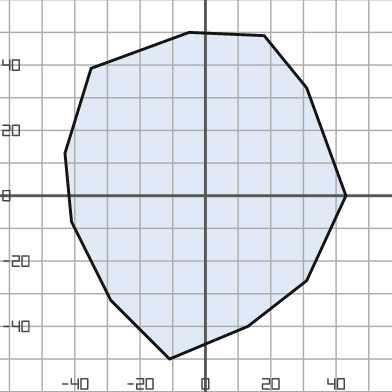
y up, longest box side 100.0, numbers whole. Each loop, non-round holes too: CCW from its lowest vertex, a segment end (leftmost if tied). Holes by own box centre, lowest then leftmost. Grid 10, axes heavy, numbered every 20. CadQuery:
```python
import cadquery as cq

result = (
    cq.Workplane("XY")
    .moveTo(-11.0, -50.0)
    .lineTo(13.0, -40.0)
    .lineTo(31.0, -26.0)
    .lineTo(43.0, 0.0)
    .lineTo(31.0, 33.0)
    .lineTo(18.0, 49.0)
    .lineTo(-5.0, 50.0)
    .lineTo(-35.0, 39.0)
    .lineTo(-43.0, 13.0)
    .lineTo(-41.0, -8.0)
    .lineTo(-29.0, -32.0)
    .close()
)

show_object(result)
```